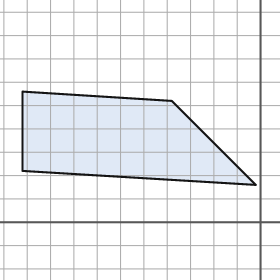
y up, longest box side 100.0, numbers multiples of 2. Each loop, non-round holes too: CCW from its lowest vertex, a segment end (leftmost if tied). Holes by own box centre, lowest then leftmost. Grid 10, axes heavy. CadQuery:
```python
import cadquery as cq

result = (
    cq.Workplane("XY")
    .moveTo(-2.0, 16.0)
    .lineTo(-38.0, 52.0)
    .lineTo(-102.0, 56.0)
    .lineTo(-102.0, 22.0)
    .close()
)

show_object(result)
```